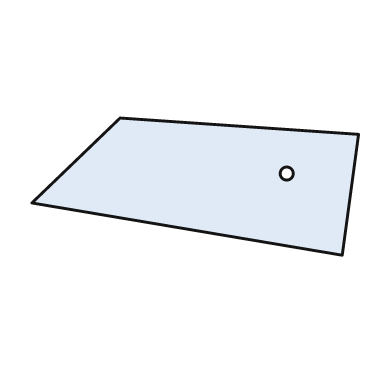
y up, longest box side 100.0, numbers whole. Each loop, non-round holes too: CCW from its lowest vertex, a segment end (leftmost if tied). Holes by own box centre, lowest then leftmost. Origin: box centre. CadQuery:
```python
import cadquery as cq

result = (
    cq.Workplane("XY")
    .moveTo(45.0, -21.0)
    .lineTo(50.0, 16.0)
    .lineTo(-23.0, 21.0)
    .lineTo(-50.0, -5.0)
    .close()
    .moveTo(28.0, 4.0)
    .circle(2.0)
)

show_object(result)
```